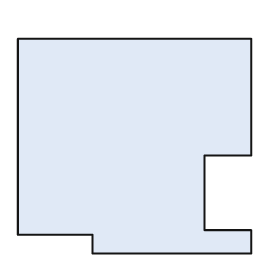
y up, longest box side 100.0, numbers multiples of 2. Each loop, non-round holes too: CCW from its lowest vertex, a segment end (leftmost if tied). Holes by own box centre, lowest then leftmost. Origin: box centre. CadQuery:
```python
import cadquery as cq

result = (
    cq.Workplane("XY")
    .moveTo(-18.0, -46.0)
    .lineTo(50.0, -46.0)
    .lineTo(50.0, -36.0)
    .lineTo(30.0, -36.0)
    .lineTo(30.0, -4.0)
    .lineTo(50.0, -4.0)
    .lineTo(50.0, 46.0)
    .lineTo(-50.0, 46.0)
    .lineTo(-50.0, -38.0)
    .lineTo(-18.0, -38.0)
    .close()
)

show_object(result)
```